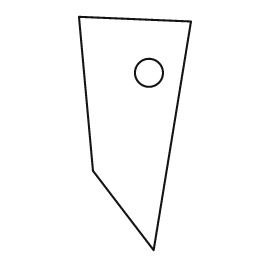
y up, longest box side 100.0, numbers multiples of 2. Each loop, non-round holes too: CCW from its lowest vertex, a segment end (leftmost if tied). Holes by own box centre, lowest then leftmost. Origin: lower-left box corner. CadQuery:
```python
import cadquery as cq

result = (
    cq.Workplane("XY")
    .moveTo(32.0, 0.0)
    .lineTo(48.0, 98.0)
    .lineTo(0.0, 100.0)
    .lineTo(6.0, 34.0)
    .close()
    .moveTo(30.0, 76.0)
    .circle(6.0)
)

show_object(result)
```